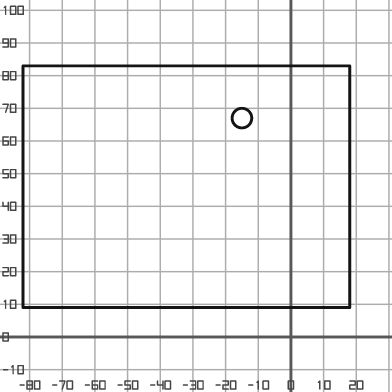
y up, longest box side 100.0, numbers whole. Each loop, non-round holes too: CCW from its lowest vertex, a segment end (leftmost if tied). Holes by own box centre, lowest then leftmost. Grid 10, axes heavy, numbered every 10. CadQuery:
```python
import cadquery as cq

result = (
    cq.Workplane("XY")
    .moveTo(-82.0, 9.0)
    .lineTo(18.0, 9.0)
    .lineTo(18.0, 83.0)
    .lineTo(-82.0, 83.0)
    .close()
    .moveTo(-15.0, 67.0)
    .circle(3.0)
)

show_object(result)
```